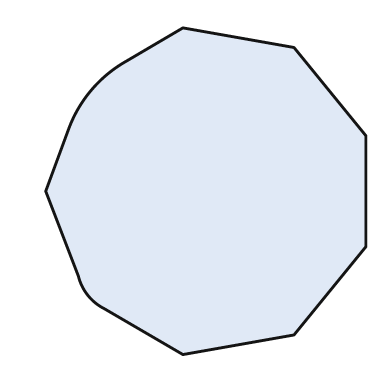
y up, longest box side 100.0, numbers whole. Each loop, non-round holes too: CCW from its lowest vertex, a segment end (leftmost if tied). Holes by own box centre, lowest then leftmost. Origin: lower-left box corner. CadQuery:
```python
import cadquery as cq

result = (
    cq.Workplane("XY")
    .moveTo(42.0, 0.0)
    .lineTo(76.0, 6.0)
    .lineTo(98.0, 33.0)
    .lineTo(98.0, 67.0)
    .lineTo(76.0, 94.0)
    .lineTo(42.0, 100.0)
    .lineTo(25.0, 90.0)
    .threePointArc((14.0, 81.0), (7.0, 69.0))
    .lineTo(0.0, 50.0)
    .lineTo(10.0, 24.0)
    .threePointArc((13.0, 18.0), (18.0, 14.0))
    .close()
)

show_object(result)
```